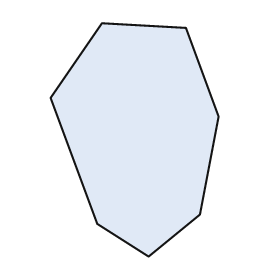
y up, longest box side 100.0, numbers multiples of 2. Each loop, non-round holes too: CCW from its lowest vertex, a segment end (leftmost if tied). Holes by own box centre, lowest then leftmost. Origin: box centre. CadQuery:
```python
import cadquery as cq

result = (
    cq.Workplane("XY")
    .moveTo(6.0, -50.0)
    .lineTo(28.0, -32.0)
    .lineTo(36.0, 10.0)
    .lineTo(22.0, 48.0)
    .lineTo(-14.0, 50.0)
    .lineTo(-36.0, 18.0)
    .lineTo(-16.0, -36.0)
    .close()
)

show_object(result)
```